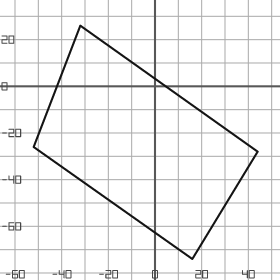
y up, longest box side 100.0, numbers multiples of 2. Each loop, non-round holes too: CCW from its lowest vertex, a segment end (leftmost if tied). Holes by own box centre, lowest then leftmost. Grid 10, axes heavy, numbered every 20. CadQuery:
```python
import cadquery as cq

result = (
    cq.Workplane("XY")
    .moveTo(16.0, -74.0)
    .lineTo(44.0, -28.0)
    .lineTo(-32.0, 26.0)
    .lineTo(-52.0, -26.0)
    .close()
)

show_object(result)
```